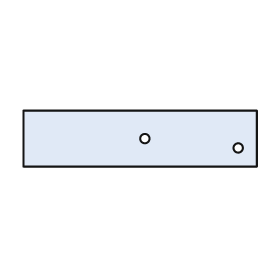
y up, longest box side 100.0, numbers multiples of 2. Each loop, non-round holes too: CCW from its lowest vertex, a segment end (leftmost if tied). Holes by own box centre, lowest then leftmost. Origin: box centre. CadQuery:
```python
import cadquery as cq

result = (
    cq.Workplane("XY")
    .moveTo(-50.0, -12.0)
    .lineTo(50.0, -12.0)
    .lineTo(50.0, 12.0)
    .lineTo(-50.0, 12.0)
    .close()
    .moveTo(42.0, -4.0)
    .circle(2.0)
    .moveTo(2.0, 0.0)
    .circle(2.0)
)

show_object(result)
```